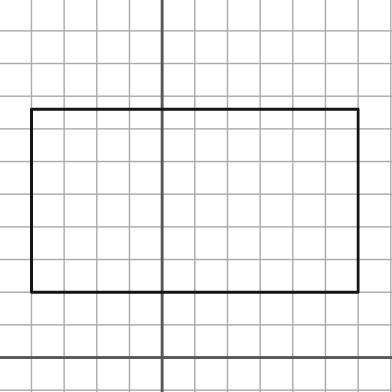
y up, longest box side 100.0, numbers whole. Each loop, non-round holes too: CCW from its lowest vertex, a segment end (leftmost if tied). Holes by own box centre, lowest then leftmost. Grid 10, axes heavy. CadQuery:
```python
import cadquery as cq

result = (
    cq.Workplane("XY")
    .moveTo(-40.0, 20.0)
    .lineTo(60.0, 20.0)
    .lineTo(60.0, 76.0)
    .lineTo(-40.0, 76.0)
    .close()
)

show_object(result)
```